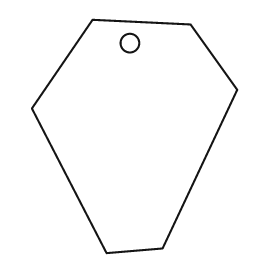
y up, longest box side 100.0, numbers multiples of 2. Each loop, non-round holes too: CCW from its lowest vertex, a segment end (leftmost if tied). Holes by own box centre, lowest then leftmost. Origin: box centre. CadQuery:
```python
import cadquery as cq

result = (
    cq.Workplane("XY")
    .moveTo(-12.0, -50.0)
    .lineTo(12.0, -48.0)
    .lineTo(44.0, 20.0)
    .lineTo(24.0, 48.0)
    .lineTo(-18.0, 50.0)
    .lineTo(-44.0, 12.0)
    .close()
    .moveTo(-2.0, 40.0)
    .circle(4.0)
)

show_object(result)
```